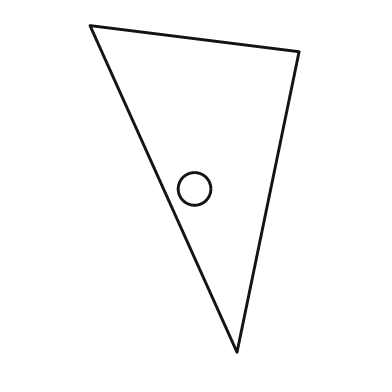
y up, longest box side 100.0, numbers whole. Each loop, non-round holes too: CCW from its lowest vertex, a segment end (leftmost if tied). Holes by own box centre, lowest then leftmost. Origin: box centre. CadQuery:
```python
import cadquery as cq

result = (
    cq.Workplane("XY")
    .moveTo(13.0, -50.0)
    .lineTo(32.0, 42.0)
    .lineTo(-32.0, 50.0)
    .close()
    .moveTo(0.0, 0.0)
    .circle(5.0)
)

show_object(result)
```